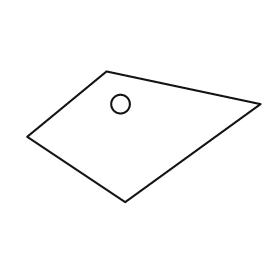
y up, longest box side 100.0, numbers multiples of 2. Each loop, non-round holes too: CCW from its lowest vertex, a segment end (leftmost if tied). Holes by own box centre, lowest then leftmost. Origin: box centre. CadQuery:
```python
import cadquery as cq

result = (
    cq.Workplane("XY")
    .moveTo(-8.0, -28.0)
    .lineTo(50.0, 14.0)
    .lineTo(-16.0, 28.0)
    .lineTo(-50.0, 0.0)
    .close()
    .moveTo(-10.0, 14.0)
    .circle(4.0)
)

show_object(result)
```